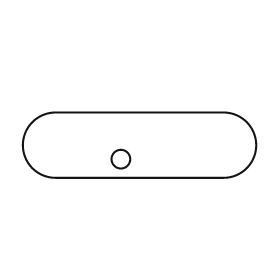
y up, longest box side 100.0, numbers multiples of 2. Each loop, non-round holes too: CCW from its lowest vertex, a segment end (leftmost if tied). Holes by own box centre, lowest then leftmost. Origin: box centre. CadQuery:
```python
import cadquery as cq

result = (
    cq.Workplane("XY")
    .moveTo(-36.0, -14.0)
    .lineTo(36.0, -14.0)
    .threePointArc((50.0, 0.0), (36.0, 14.0))
    .lineTo(-36.0, 14.0)
    .threePointArc((-50.0, 0.0), (-36.0, -14.0))
    .close()
    .moveTo(-8.0, -6.0)
    .circle(4.0)
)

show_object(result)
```